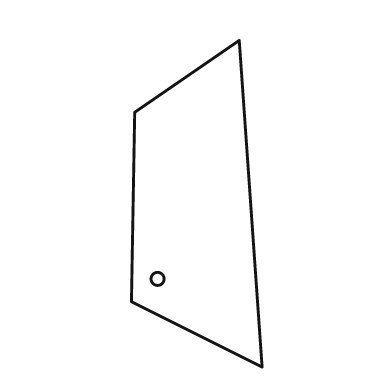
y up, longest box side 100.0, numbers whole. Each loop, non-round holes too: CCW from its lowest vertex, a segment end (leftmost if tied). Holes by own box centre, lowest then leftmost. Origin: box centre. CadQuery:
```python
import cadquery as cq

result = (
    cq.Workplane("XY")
    .moveTo(20.0, -50.0)
    .lineTo(13.0, 50.0)
    .lineTo(-19.0, 28.0)
    .lineTo(-20.0, -30.0)
    .close()
    .moveTo(-12.0, -23.0)
    .circle(2.0)
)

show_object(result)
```